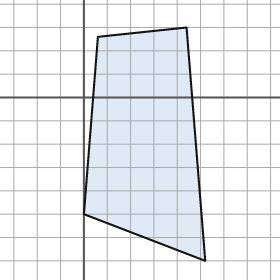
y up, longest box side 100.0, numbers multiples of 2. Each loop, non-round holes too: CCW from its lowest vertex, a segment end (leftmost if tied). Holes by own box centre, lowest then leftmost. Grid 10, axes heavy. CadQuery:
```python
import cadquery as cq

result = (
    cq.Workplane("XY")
    .moveTo(52.0, -70.0)
    .lineTo(44.0, 30.0)
    .lineTo(6.0, 26.0)
    .lineTo(0.0, -50.0)
    .close()
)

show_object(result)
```